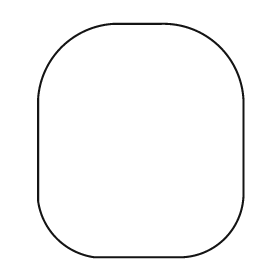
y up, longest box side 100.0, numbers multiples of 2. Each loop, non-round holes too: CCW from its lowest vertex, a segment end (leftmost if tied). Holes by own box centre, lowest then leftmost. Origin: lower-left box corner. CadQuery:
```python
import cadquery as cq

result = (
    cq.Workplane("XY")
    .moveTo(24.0, 0.0)
    .lineTo(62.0, 0.0)
    .threePointArc((80.0, 8.0), (88.0, 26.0))
    .lineTo(88.0, 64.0)
    .threePointArc((78.0, 90.0), (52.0, 100.0))
    .lineTo(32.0, 100.0)
    .threePointArc((10.0, 90.0), (0.0, 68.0))
    .lineTo(0.0, 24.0)
    .threePointArc((8.0, 8.0), (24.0, 0.0))
    .close()
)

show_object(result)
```